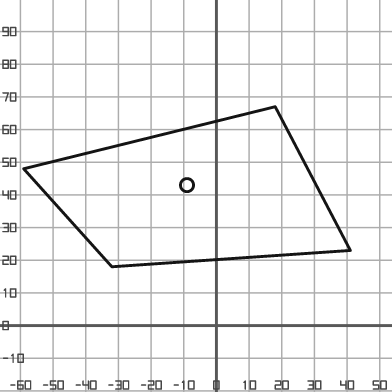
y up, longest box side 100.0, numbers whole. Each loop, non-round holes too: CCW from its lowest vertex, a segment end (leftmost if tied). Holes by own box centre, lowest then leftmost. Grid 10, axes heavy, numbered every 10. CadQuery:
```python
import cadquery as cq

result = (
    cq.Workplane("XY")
    .moveTo(-32.0, 18.0)
    .lineTo(41.0, 23.0)
    .lineTo(18.0, 67.0)
    .lineTo(-59.0, 48.0)
    .close()
    .moveTo(-9.0, 43.0)
    .circle(2.0)
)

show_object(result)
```